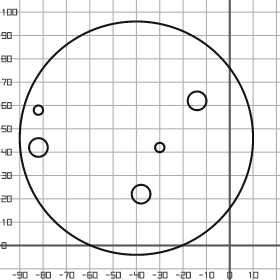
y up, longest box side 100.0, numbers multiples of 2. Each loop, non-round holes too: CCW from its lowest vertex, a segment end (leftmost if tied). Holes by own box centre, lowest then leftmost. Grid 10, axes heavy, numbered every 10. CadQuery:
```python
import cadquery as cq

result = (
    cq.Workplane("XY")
    .moveTo(-40.0, 46.0)
    .circle(50.0)
    .moveTo(-38.0, 22.0)
    .circle(4.0)
    .moveTo(-82.0, 42.0)
    .circle(4.0)
    .moveTo(-30.0, 42.0)
    .circle(2.0)
    .moveTo(-82.0, 58.0)
    .circle(2.0)
    .moveTo(-14.0, 62.0)
    .circle(4.0)
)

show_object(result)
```